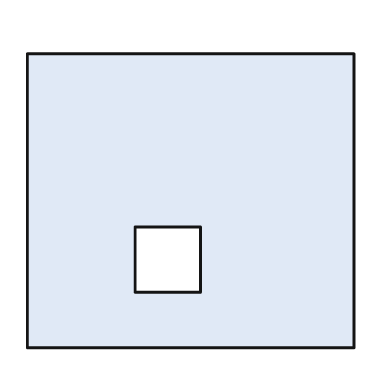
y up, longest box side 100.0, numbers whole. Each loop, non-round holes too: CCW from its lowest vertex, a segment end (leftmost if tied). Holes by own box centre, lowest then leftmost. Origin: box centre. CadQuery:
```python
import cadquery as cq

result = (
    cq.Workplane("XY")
    .moveTo(-50.0, -45.0)
    .lineTo(50.0, -45.0)
    .lineTo(50.0, 45.0)
    .lineTo(-50.0, 45.0)
    .close()
    .moveTo(-17.0, -28.0)
    .lineTo(3.0, -28.0)
    .lineTo(3.0, -8.0)
    .lineTo(-17.0, -8.0)
    .close()
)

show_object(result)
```